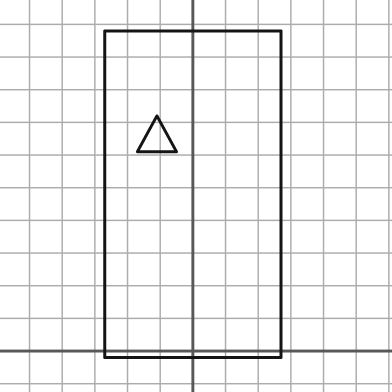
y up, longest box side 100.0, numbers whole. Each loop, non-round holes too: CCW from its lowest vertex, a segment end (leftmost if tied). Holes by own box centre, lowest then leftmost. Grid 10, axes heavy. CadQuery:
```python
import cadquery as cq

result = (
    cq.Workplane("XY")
    .moveTo(-27.0, -2.0)
    .lineTo(27.0, -2.0)
    .lineTo(27.0, 98.0)
    .lineTo(-27.0, 98.0)
    .close()
    .moveTo(-17.0, 61.0)
    .lineTo(-5.0, 61.0)
    .lineTo(-11.0, 72.0)
    .close()
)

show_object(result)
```